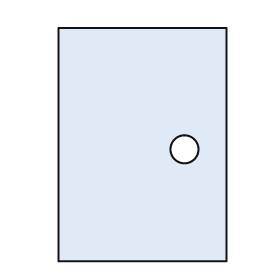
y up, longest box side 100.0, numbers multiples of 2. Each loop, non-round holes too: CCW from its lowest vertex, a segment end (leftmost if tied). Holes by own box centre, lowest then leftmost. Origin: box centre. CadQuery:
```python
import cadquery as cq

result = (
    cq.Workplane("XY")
    .moveTo(-36.0, -50.0)
    .lineTo(36.0, -50.0)
    .lineTo(36.0, 50.0)
    .lineTo(-36.0, 50.0)
    .close()
    .moveTo(18.0, -2.0)
    .circle(6.0)
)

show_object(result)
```